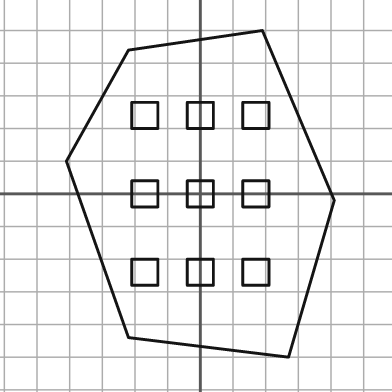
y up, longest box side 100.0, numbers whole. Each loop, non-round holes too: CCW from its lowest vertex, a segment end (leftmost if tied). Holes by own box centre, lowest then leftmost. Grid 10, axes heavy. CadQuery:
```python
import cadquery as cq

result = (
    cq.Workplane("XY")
    .moveTo(27.0, -50.0)
    .lineTo(41.0, -2.0)
    .lineTo(19.0, 50.0)
    .lineTo(-22.0, 44.0)
    .lineTo(-41.0, 10.0)
    .lineTo(-22.0, -44.0)
    .close()
    .moveTo(-21.0, -28.0)
    .lineTo(-13.0, -28.0)
    .lineTo(-13.0, -20.0)
    .lineTo(-21.0, -20.0)
    .close()
    .moveTo(-4.0, -28.0)
    .lineTo(4.0, -28.0)
    .lineTo(4.0, -20.0)
    .lineTo(-4.0, -20.0)
    .close()
    .moveTo(13.0, -28.0)
    .lineTo(21.0, -28.0)
    .lineTo(21.0, -20.0)
    .lineTo(13.0, -20.0)
    .close()
    .moveTo(-21.0, -4.0)
    .lineTo(-13.0, -4.0)
    .lineTo(-13.0, 4.0)
    .lineTo(-21.0, 4.0)
    .close()
    .moveTo(-4.0, -4.0)
    .lineTo(4.0, -4.0)
    .lineTo(4.0, 4.0)
    .lineTo(-4.0, 4.0)
    .close()
    .moveTo(13.0, -4.0)
    .lineTo(21.0, -4.0)
    .lineTo(21.0, 4.0)
    .lineTo(13.0, 4.0)
    .close()
    .moveTo(-21.0, 20.0)
    .lineTo(-13.0, 20.0)
    .lineTo(-13.0, 28.0)
    .lineTo(-21.0, 28.0)
    .close()
    .moveTo(-4.0, 20.0)
    .lineTo(4.0, 20.0)
    .lineTo(4.0, 28.0)
    .lineTo(-4.0, 28.0)
    .close()
    .moveTo(13.0, 20.0)
    .lineTo(21.0, 20.0)
    .lineTo(21.0, 28.0)
    .lineTo(13.0, 28.0)
    .close()
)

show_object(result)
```